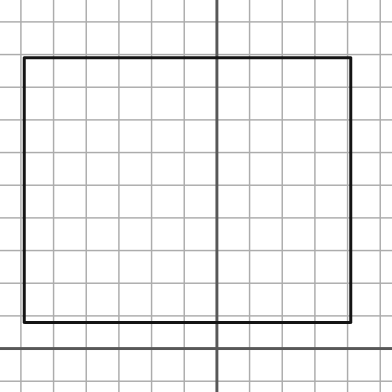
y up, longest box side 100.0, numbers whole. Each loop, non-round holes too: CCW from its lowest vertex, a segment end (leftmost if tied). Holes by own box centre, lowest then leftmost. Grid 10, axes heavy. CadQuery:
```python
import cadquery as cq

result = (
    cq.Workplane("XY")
    .moveTo(-59.0, 8.0)
    .lineTo(41.0, 8.0)
    .lineTo(41.0, 89.0)
    .lineTo(-59.0, 89.0)
    .close()
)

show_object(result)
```